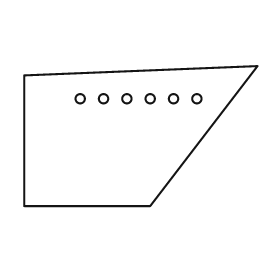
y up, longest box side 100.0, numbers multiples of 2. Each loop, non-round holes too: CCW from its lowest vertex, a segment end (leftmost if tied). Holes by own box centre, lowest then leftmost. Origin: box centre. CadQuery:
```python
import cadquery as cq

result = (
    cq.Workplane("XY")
    .moveTo(-50.0, -30.0)
    .lineTo(4.0, -30.0)
    .lineTo(50.0, 30.0)
    .lineTo(-50.0, 26.0)
    .close()
    .moveTo(-26.0, 16.0)
    .circle(2.0)
    .moveTo(-16.0, 16.0)
    .circle(2.0)
    .moveTo(-6.0, 16.0)
    .circle(2.0)
    .moveTo(4.0, 16.0)
    .circle(2.0)
    .moveTo(14.0, 16.0)
    .circle(2.0)
    .moveTo(24.0, 16.0)
    .circle(2.0)
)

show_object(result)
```